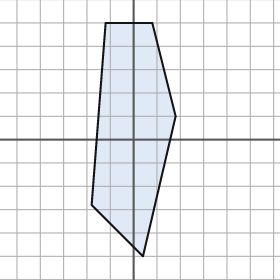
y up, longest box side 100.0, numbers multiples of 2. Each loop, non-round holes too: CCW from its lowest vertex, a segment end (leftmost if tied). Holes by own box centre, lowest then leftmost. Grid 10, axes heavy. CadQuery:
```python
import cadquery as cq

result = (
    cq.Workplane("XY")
    .moveTo(4.0, -50.0)
    .lineTo(18.0, 10.0)
    .lineTo(8.0, 50.0)
    .lineTo(-12.0, 50.0)
    .lineTo(-18.0, -28.0)
    .close()
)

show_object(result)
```